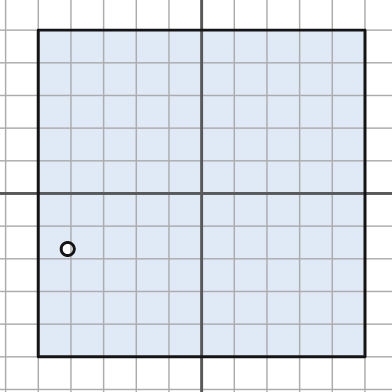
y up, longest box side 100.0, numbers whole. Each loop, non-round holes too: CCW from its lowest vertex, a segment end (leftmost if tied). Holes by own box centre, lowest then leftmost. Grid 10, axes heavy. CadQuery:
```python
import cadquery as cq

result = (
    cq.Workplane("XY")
    .moveTo(-50.0, -50.0)
    .lineTo(50.0, -50.0)
    .lineTo(50.0, 50.0)
    .lineTo(-50.0, 50.0)
    .close()
    .moveTo(-41.0, -17.0)
    .circle(2.0)
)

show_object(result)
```